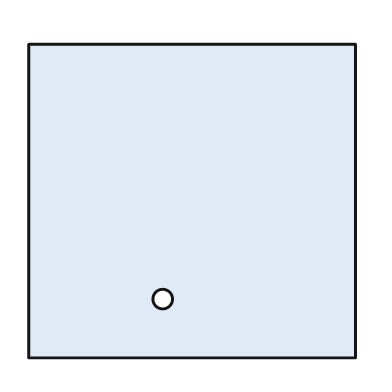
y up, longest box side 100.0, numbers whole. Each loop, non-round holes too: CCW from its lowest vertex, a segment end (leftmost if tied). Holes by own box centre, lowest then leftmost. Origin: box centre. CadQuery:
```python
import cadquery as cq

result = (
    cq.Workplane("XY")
    .moveTo(-50.0, -48.0)
    .lineTo(50.0, -48.0)
    .lineTo(50.0, 48.0)
    .lineTo(-50.0, 48.0)
    .close()
    .moveTo(-9.0, -30.0)
    .circle(3.0)
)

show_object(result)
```